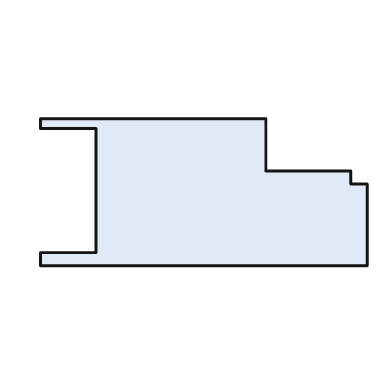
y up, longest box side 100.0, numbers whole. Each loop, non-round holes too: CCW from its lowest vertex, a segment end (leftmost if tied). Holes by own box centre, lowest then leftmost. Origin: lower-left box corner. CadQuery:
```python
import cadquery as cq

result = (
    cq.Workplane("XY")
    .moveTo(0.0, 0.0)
    .lineTo(100.0, 0.0)
    .lineTo(100.0, 25.0)
    .lineTo(95.0, 25.0)
    .lineTo(95.0, 29.0)
    .lineTo(69.0, 29.0)
    .lineTo(69.0, 45.0)
    .lineTo(0.0, 45.0)
    .lineTo(0.0, 42.0)
    .lineTo(17.0, 42.0)
    .lineTo(17.0, 4.0)
    .lineTo(0.0, 4.0)
    .close()
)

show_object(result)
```